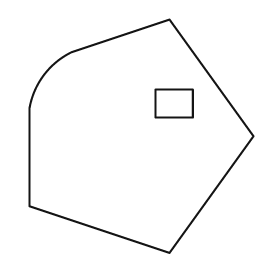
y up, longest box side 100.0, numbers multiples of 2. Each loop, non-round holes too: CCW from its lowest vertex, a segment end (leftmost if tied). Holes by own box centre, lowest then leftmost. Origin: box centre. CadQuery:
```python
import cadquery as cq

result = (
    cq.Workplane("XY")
    .moveTo(12.0, -50.0)
    .lineTo(48.0, 0.0)
    .lineTo(12.0, 50.0)
    .lineTo(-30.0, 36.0)
    .threePointArc((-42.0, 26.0), (-48.0, 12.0))
    .lineTo(-48.0, -30.0)
    .close()
    .moveTo(6.0, 8.0)
    .lineTo(22.0, 8.0)
    .lineTo(22.0, 20.0)
    .lineTo(6.0, 20.0)
    .close()
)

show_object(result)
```